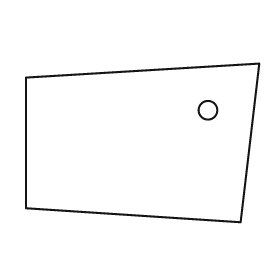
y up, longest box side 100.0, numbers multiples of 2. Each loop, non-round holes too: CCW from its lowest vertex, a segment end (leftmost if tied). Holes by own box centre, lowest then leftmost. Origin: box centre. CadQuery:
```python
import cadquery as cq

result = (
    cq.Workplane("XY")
    .moveTo(42.0, -34.0)
    .lineTo(50.0, 34.0)
    .lineTo(-50.0, 28.0)
    .lineTo(-50.0, -28.0)
    .close()
    .moveTo(28.0, 14.0)
    .circle(4.0)
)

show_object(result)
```